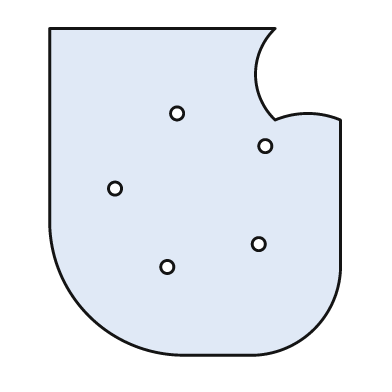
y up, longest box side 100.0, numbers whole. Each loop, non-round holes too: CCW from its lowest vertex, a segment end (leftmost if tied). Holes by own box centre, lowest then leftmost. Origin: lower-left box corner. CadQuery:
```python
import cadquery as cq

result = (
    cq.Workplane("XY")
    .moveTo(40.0, 0.0)
    .lineTo(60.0, 0.0)
    .threePointArc((81.0, 8.0), (89.0, 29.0))
    .lineTo(89.0, 72.0)
    .threePointArc((79.0, 74.0), (69.0, 72.0))
    .threePointArc((63.0, 86.0), (69.0, 100.0))
    .lineTo(0.0, 100.0)
    .lineTo(0.0, 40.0)
    .threePointArc((12.0, 12.0), (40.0, 0.0))
    .close()
    .moveTo(36.0, 27.0)
    .circle(2.0)
    .moveTo(64.0, 34.0)
    .circle(2.0)
    .moveTo(20.0, 51.0)
    .circle(2.0)
    .moveTo(66.0, 64.0)
    .circle(2.0)
    .moveTo(39.0, 74.0)
    .circle(2.0)
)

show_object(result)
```